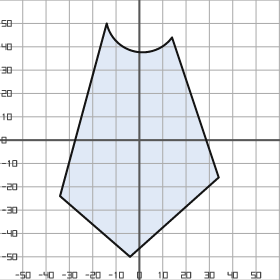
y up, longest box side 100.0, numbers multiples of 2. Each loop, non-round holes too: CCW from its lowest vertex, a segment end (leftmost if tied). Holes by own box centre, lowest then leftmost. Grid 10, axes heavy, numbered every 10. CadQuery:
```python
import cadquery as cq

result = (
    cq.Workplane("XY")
    .moveTo(-4.0, -50.0)
    .lineTo(34.0, -16.0)
    .lineTo(14.0, 44.0)
    .threePointArc((-2.0, 38.0), (-14.0, 50.0))
    .lineTo(-34.0, -24.0)
    .close()
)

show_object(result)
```